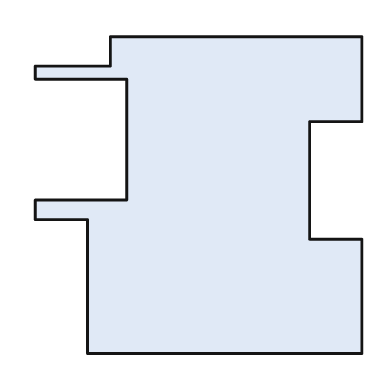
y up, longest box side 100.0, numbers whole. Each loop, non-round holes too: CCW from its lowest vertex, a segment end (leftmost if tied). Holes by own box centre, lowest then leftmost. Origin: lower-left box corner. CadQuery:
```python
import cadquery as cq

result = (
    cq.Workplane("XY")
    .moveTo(16.0, 0.0)
    .lineTo(100.0, 0.0)
    .lineTo(100.0, 35.0)
    .lineTo(84.0, 35.0)
    .lineTo(84.0, 71.0)
    .lineTo(100.0, 71.0)
    .lineTo(100.0, 97.0)
    .lineTo(23.0, 97.0)
    .lineTo(23.0, 88.0)
    .lineTo(0.0, 88.0)
    .lineTo(0.0, 84.0)
    .lineTo(28.0, 84.0)
    .lineTo(28.0, 47.0)
    .lineTo(0.0, 47.0)
    .lineTo(0.0, 41.0)
    .lineTo(16.0, 41.0)
    .close()
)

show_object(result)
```